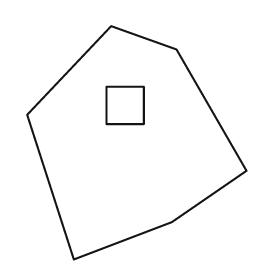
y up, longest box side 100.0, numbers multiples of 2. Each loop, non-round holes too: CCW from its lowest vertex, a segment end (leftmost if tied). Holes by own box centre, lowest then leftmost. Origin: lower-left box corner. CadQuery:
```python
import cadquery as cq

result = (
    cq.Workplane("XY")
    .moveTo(20.0, 0.0)
    .lineTo(62.0, 16.0)
    .lineTo(94.0, 38.0)
    .lineTo(64.0, 90.0)
    .lineTo(36.0, 100.0)
    .lineTo(0.0, 62.0)
    .close()
    .moveTo(34.0, 58.0)
    .lineTo(50.0, 58.0)
    .lineTo(50.0, 74.0)
    .lineTo(34.0, 74.0)
    .close()
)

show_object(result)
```